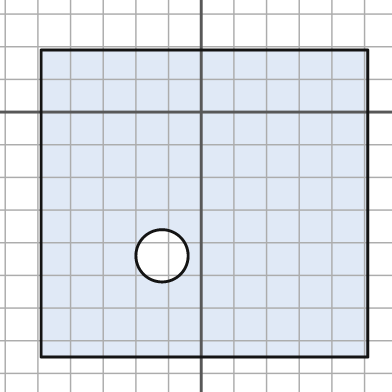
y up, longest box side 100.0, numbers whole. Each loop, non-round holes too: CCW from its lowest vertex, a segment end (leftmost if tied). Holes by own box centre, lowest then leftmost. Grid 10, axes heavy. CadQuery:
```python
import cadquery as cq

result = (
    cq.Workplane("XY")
    .moveTo(-49.0, -75.0)
    .lineTo(51.0, -75.0)
    .lineTo(51.0, 19.0)
    .lineTo(-49.0, 19.0)
    .close()
    .moveTo(-12.0, -44.0)
    .circle(8.0)
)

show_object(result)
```